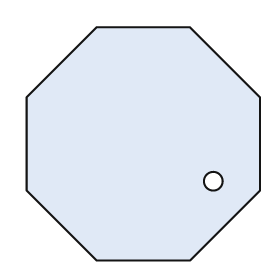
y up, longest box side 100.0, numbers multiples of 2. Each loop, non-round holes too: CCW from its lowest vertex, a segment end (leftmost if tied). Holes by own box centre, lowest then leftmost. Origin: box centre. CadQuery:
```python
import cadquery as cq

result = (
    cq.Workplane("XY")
    .moveTo(-20.0, -50.0)
    .lineTo(20.0, -50.0)
    .lineTo(50.0, -20.0)
    .lineTo(50.0, 20.0)
    .lineTo(20.0, 50.0)
    .lineTo(-20.0, 50.0)
    .lineTo(-50.0, 20.0)
    .lineTo(-50.0, -20.0)
    .close()
    .moveTo(30.0, -16.0)
    .circle(4.0)
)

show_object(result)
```